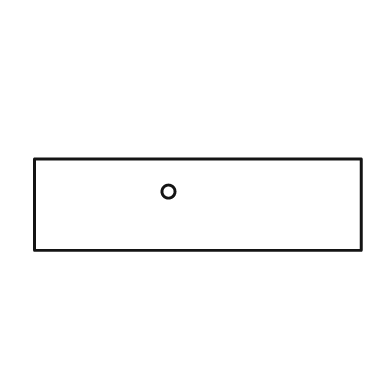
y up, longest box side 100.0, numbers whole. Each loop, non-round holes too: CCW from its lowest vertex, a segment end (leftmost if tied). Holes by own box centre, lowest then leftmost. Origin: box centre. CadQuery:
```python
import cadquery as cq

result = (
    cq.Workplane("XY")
    .moveTo(-50.0, -14.0)
    .lineTo(50.0, -14.0)
    .lineTo(50.0, 14.0)
    .lineTo(-50.0, 14.0)
    .close()
    .moveTo(-9.0, 4.0)
    .circle(2.0)
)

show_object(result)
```